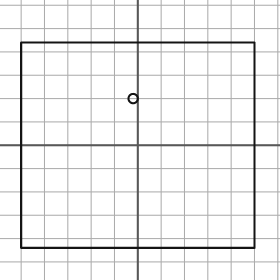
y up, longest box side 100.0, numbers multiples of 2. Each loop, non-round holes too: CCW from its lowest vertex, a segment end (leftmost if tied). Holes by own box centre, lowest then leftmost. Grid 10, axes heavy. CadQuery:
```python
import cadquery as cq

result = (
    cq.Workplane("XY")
    .moveTo(-50.0, -44.0)
    .lineTo(50.0, -44.0)
    .lineTo(50.0, 44.0)
    .lineTo(-50.0, 44.0)
    .close()
    .moveTo(-2.0, 20.0)
    .circle(2.0)
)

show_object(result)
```